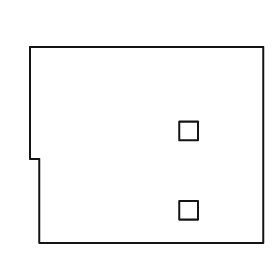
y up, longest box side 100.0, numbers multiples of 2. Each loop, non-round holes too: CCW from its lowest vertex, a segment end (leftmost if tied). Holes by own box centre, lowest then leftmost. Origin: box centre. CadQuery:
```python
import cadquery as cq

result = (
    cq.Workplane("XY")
    .moveTo(-46.0, -42.0)
    .lineTo(50.0, -42.0)
    .lineTo(50.0, 42.0)
    .lineTo(-50.0, 42.0)
    .lineTo(-50.0, -6.0)
    .lineTo(-46.0, -6.0)
    .close()
    .moveTo(14.0, -32.0)
    .lineTo(22.0, -32.0)
    .lineTo(22.0, -24.0)
    .lineTo(14.0, -24.0)
    .close()
    .moveTo(14.0, 2.0)
    .lineTo(22.0, 2.0)
    .lineTo(22.0, 10.0)
    .lineTo(14.0, 10.0)
    .close()
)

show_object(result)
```